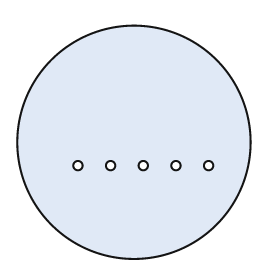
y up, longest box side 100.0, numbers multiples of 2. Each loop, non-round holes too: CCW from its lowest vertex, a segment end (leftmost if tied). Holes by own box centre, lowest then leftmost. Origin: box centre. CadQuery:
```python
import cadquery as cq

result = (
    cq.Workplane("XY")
    .moveTo(0.0, 0.0)
    .circle(50.0)
    .moveTo(-24.0, -10.0)
    .circle(2.0)
    .moveTo(-10.0, -10.0)
    .circle(2.0)
    .moveTo(4.0, -10.0)
    .circle(2.0)
    .moveTo(18.0, -10.0)
    .circle(2.0)
    .moveTo(32.0, -10.0)
    .circle(2.0)
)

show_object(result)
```